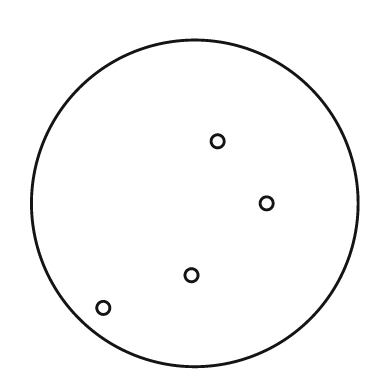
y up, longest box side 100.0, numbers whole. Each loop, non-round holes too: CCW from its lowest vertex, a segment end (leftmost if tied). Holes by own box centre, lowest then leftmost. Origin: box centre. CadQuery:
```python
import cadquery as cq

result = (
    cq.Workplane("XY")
    .moveTo(0.0, 0.0)
    .circle(50.0)
    .moveTo(-28.0, -32.0)
    .circle(2.0)
    .moveTo(-1.0, -22.0)
    .circle(2.0)
    .moveTo(22.0, 0.0)
    .circle(2.0)
    .moveTo(7.0, 19.0)
    .circle(2.0)
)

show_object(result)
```